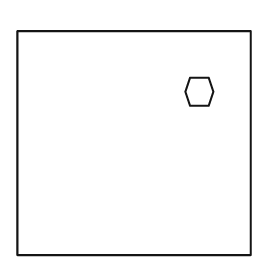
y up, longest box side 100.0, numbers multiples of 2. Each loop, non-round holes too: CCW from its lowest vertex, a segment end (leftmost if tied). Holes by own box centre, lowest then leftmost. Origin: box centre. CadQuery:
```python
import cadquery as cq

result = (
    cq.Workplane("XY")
    .moveTo(-50.0, -48.0)
    .lineTo(50.0, -48.0)
    .lineTo(50.0, 48.0)
    .lineTo(-50.0, 48.0)
    .close()
    .moveTo(24.0, 16.0)
    .lineTo(32.0, 16.0)
    .lineTo(34.0, 22.0)
    .lineTo(32.0, 28.0)
    .lineTo(24.0, 28.0)
    .lineTo(22.0, 22.0)
    .close()
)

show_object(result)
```